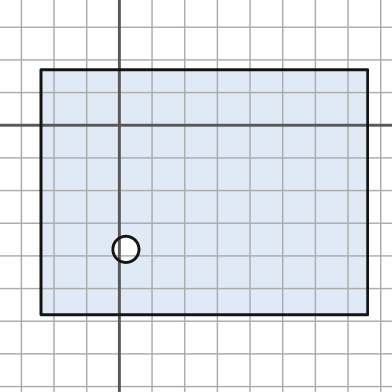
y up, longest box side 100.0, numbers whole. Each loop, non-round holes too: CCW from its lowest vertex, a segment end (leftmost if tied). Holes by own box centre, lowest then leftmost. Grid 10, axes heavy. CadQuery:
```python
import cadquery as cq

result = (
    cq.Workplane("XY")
    .moveTo(-24.0, -58.0)
    .lineTo(76.0, -58.0)
    .lineTo(76.0, 17.0)
    .lineTo(-24.0, 17.0)
    .close()
    .moveTo(2.0, -38.0)
    .circle(4.0)
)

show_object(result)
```